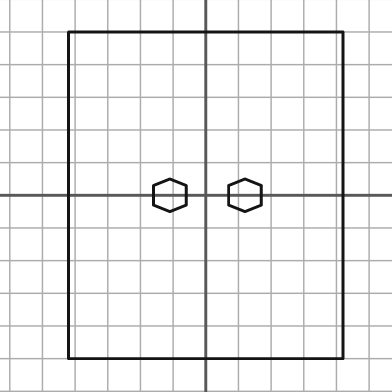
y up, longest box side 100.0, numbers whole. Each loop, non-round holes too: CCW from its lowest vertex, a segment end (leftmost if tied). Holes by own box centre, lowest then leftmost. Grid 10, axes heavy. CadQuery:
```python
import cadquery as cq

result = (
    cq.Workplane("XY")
    .moveTo(-42.0, -50.0)
    .lineTo(42.0, -50.0)
    .lineTo(42.0, 50.0)
    .lineTo(-42.0, 50.0)
    .close()
    .moveTo(-11.0, -5.0)
    .lineTo(-6.0, -3.0)
    .lineTo(-6.0, 3.0)
    .lineTo(-11.0, 5.0)
    .lineTo(-16.0, 3.0)
    .lineTo(-16.0, -3.0)
    .close()
    .moveTo(12.0, -5.0)
    .lineTo(17.0, -3.0)
    .lineTo(17.0, 3.0)
    .lineTo(12.0, 5.0)
    .lineTo(7.0, 3.0)
    .lineTo(7.0, -3.0)
    .close()
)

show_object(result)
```